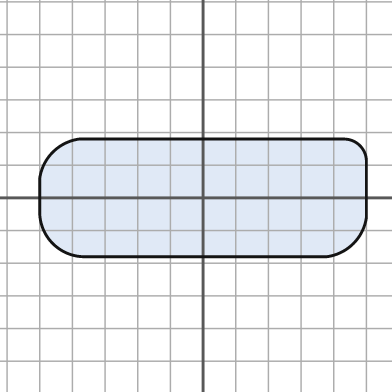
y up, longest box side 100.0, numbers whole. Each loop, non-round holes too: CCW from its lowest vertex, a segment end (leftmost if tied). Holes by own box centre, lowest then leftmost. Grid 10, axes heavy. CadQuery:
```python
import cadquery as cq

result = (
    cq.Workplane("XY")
    .moveTo(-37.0, -18.0)
    .lineTo(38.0, -18.0)
    .threePointArc((46.0, -14.0), (50.0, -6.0))
    .lineTo(50.0, 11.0)
    .threePointArc((48.0, 16.0), (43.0, 18.0))
    .lineTo(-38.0, 18.0)
    .threePointArc((-46.0, 14.0), (-50.0, 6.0))
    .lineTo(-50.0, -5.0)
    .threePointArc((-46.0, -14.0), (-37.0, -18.0))
    .close()
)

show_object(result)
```